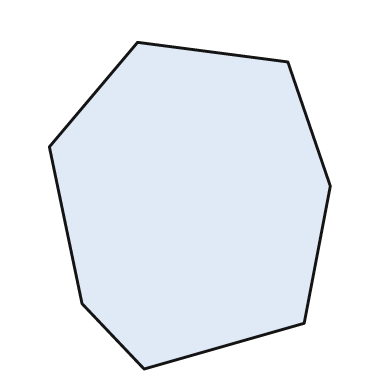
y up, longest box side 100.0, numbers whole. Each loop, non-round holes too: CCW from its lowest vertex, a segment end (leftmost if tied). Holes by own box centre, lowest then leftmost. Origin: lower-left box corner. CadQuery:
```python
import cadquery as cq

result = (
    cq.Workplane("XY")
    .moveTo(29.0, 0.0)
    .lineTo(78.0, 14.0)
    .lineTo(86.0, 56.0)
    .lineTo(73.0, 94.0)
    .lineTo(27.0, 100.0)
    .lineTo(0.0, 68.0)
    .lineTo(10.0, 20.0)
    .close()
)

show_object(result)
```